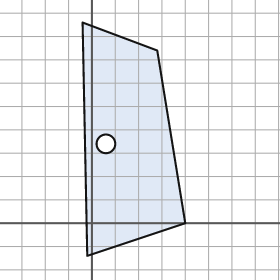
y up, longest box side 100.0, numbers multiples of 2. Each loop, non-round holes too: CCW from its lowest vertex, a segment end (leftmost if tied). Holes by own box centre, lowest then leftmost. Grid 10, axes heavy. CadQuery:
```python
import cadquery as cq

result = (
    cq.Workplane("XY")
    .moveTo(-2.0, -14.0)
    .lineTo(40.0, 0.0)
    .lineTo(28.0, 74.0)
    .lineTo(-4.0, 86.0)
    .close()
    .moveTo(6.0, 34.0)
    .circle(4.0)
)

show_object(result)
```